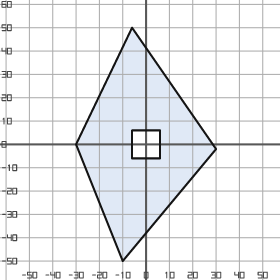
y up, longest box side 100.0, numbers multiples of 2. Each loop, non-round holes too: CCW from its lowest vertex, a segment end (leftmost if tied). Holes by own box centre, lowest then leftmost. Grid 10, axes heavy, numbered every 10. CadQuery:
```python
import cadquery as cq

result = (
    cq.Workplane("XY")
    .moveTo(-10.0, -50.0)
    .lineTo(30.0, -2.0)
    .lineTo(-6.0, 50.0)
    .lineTo(-30.0, 0.0)
    .close()
    .moveTo(-6.0, -6.0)
    .lineTo(6.0, -6.0)
    .lineTo(6.0, 6.0)
    .lineTo(-6.0, 6.0)
    .close()
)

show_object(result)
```